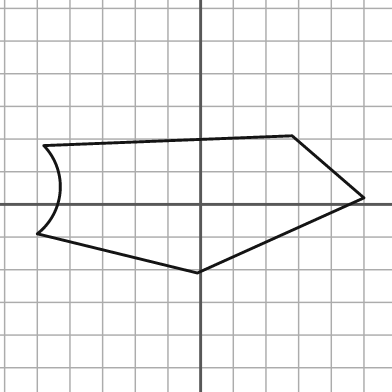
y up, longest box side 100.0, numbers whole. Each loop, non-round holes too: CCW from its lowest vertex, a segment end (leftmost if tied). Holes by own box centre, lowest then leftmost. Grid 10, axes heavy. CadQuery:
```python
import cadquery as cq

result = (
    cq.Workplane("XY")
    .moveTo(-1.0, -21.0)
    .lineTo(50.0, 2.0)
    .lineTo(28.0, 21.0)
    .lineTo(-48.0, 18.0)
    .threePointArc((-43.0, 4.0), (-50.0, -9.0))
    .close()
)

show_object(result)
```